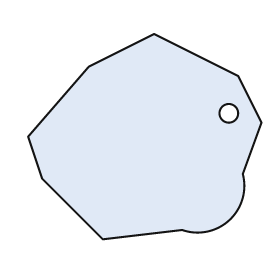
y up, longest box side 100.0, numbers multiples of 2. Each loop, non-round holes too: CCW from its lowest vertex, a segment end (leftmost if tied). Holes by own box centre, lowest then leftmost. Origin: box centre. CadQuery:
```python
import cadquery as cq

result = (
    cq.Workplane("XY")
    .moveTo(-18.0, -44.0)
    .lineTo(16.0, -40.0)
    .threePointArc((36.0, -36.0), (42.0, -16.0))
    .lineTo(50.0, 6.0)
    .lineTo(40.0, 26.0)
    .lineTo(4.0, 44.0)
    .lineTo(-24.0, 30.0)
    .lineTo(-50.0, 0.0)
    .lineTo(-44.0, -18.0)
    .close()
    .moveTo(36.0, 10.0)
    .circle(4.0)
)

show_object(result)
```